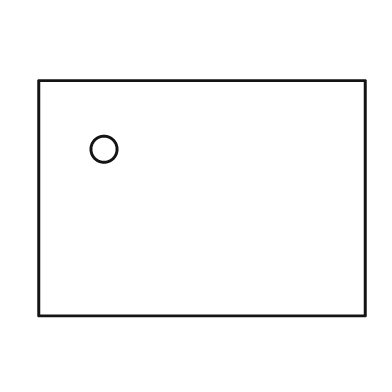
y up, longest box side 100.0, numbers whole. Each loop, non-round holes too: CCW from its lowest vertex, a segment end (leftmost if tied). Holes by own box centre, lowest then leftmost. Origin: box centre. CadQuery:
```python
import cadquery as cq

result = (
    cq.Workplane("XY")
    .moveTo(-50.0, -36.0)
    .lineTo(50.0, -36.0)
    .lineTo(50.0, 36.0)
    .lineTo(-50.0, 36.0)
    .close()
    .moveTo(-30.0, 15.0)
    .circle(4.0)
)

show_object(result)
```